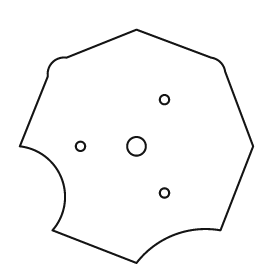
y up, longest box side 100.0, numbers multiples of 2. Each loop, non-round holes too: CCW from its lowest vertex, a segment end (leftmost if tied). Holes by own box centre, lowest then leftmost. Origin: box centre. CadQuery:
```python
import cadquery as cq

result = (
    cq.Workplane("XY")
    .moveTo(0.0, -50.0)
    .threePointArc((16.0, -38.0), (36.0, -36.0))
    .lineTo(50.0, 0.0)
    .lineTo(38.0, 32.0)
    .threePointArc((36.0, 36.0), (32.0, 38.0))
    .lineTo(0.0, 50.0)
    .lineTo(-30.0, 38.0)
    .threePointArc((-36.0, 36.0), (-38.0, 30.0))
    .lineTo(-50.0, 0.0)
    .threePointArc((-32.0, -14.0), (-36.0, -36.0))
    .close()
    .moveTo(12.0, -20.0)
    .circle(2.0)
    .moveTo(-24.0, 0.0)
    .circle(2.0)
    .moveTo(0.0, 0.0)
    .circle(4.0)
    .moveTo(12.0, 20.0)
    .circle(2.0)
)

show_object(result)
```